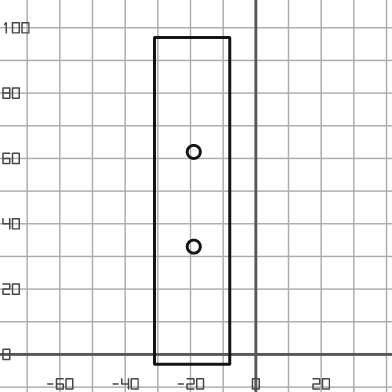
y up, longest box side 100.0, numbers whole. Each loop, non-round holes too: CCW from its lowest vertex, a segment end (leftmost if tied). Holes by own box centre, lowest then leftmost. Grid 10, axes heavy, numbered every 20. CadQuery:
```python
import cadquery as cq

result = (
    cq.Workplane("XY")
    .moveTo(-31.0, -3.0)
    .lineTo(-8.0, -3.0)
    .lineTo(-8.0, 97.0)
    .lineTo(-31.0, 97.0)
    .close()
    .moveTo(-19.0, 33.0)
    .circle(2.0)
    .moveTo(-19.0, 62.0)
    .circle(2.0)
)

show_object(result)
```